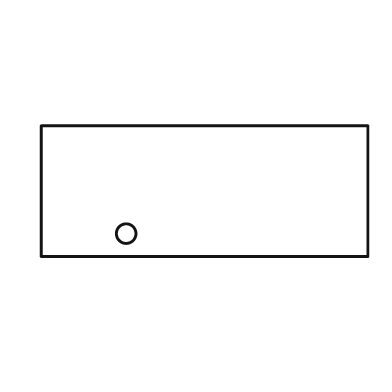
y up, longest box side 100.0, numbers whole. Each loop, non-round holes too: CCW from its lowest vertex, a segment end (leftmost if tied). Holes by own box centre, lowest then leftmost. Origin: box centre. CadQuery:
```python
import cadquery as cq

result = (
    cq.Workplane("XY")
    .moveTo(-50.0, -20.0)
    .lineTo(50.0, -20.0)
    .lineTo(50.0, 20.0)
    .lineTo(-50.0, 20.0)
    .close()
    .moveTo(-24.0, -13.0)
    .circle(3.0)
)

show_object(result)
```